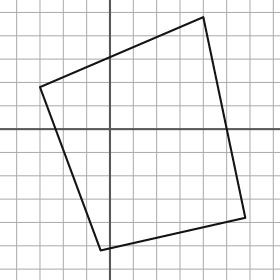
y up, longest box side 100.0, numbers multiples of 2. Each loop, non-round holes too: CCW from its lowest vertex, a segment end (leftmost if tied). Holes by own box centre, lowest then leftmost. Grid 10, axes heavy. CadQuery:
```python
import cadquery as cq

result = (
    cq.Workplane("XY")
    .moveTo(-4.0, -52.0)
    .lineTo(58.0, -38.0)
    .lineTo(40.0, 48.0)
    .lineTo(-30.0, 18.0)
    .close()
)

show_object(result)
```